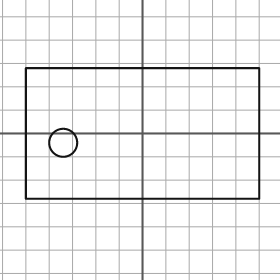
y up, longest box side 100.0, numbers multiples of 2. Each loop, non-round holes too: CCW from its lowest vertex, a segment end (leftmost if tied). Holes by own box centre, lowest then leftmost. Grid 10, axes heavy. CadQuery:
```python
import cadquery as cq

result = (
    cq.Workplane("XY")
    .moveTo(-50.0, -28.0)
    .lineTo(50.0, -28.0)
    .lineTo(50.0, 28.0)
    .lineTo(-50.0, 28.0)
    .close()
    .moveTo(-34.0, -4.0)
    .circle(6.0)
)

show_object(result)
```